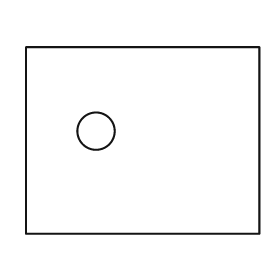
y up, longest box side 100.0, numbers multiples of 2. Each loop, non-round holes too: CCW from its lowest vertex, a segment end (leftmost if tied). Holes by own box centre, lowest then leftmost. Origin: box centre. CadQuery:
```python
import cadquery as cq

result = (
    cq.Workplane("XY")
    .moveTo(-50.0, -40.0)
    .lineTo(50.0, -40.0)
    .lineTo(50.0, 40.0)
    .lineTo(-50.0, 40.0)
    .close()
    .moveTo(-20.0, 4.0)
    .circle(8.0)
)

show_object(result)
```